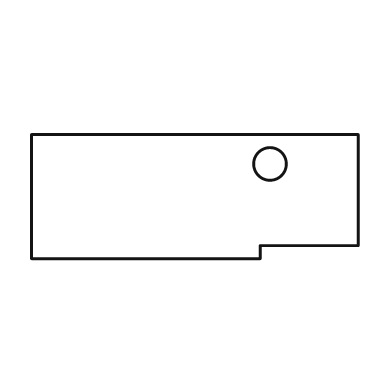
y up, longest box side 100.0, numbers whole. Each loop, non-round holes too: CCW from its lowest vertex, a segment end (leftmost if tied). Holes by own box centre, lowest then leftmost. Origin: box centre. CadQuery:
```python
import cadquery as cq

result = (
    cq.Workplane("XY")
    .moveTo(-50.0, -19.0)
    .lineTo(20.0, -19.0)
    .lineTo(20.0, -15.0)
    .lineTo(50.0, -15.0)
    .lineTo(50.0, 19.0)
    .lineTo(-50.0, 19.0)
    .close()
    .moveTo(23.0, 10.0)
    .circle(5.0)
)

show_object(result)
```